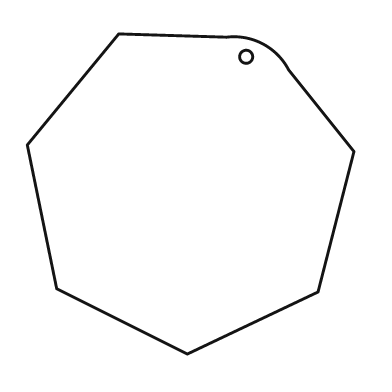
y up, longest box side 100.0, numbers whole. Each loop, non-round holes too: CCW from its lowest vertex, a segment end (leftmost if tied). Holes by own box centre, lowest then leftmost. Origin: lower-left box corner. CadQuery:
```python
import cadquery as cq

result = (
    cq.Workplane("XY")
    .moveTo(49.0, 0.0)
    .lineTo(89.0, 19.0)
    .lineTo(100.0, 62.0)
    .lineTo(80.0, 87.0)
    .threePointArc((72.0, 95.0), (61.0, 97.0))
    .lineTo(28.0, 98.0)
    .lineTo(0.0, 64.0)
    .lineTo(9.0, 20.0)
    .close()
    .moveTo(67.0, 91.0)
    .circle(2.0)
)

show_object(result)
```